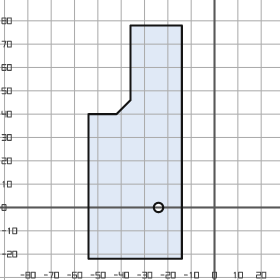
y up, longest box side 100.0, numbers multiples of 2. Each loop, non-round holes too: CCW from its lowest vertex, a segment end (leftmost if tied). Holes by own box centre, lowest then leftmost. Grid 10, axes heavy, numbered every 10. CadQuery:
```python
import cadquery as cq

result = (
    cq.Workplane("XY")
    .moveTo(-54.0, -22.0)
    .lineTo(-14.0, -22.0)
    .lineTo(-14.0, 78.0)
    .lineTo(-36.0, 78.0)
    .lineTo(-36.0, 46.0)
    .lineTo(-42.0, 40.0)
    .lineTo(-54.0, 40.0)
    .close()
    .moveTo(-24.0, 0.0)
    .circle(2.0)
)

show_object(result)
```